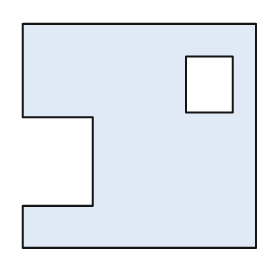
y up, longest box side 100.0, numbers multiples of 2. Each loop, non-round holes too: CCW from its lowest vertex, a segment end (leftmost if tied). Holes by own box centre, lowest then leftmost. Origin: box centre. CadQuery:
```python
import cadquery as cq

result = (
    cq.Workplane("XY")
    .moveTo(-50.0, -48.0)
    .lineTo(50.0, -48.0)
    .lineTo(50.0, 48.0)
    .lineTo(-50.0, 48.0)
    .lineTo(-50.0, 8.0)
    .lineTo(-20.0, 8.0)
    .lineTo(-20.0, -30.0)
    .lineTo(-50.0, -30.0)
    .close()
    .moveTo(20.0, 10.0)
    .lineTo(40.0, 10.0)
    .lineTo(40.0, 34.0)
    .lineTo(20.0, 34.0)
    .close()
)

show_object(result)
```